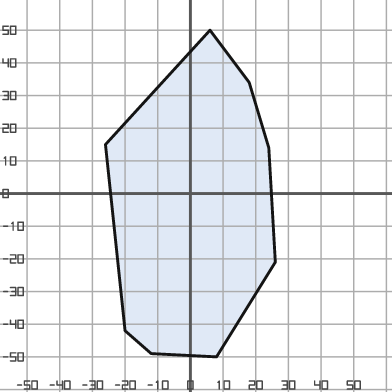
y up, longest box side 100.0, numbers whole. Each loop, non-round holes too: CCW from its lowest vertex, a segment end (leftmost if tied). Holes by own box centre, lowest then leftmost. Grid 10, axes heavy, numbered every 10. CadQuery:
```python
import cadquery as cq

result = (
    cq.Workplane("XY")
    .moveTo(8.0, -50.0)
    .lineTo(26.0, -21.0)
    .lineTo(24.0, 14.0)
    .lineTo(18.0, 34.0)
    .lineTo(6.0, 50.0)
    .lineTo(-26.0, 15.0)
    .lineTo(-20.0, -42.0)
    .lineTo(-12.0, -49.0)
    .close()
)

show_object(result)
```